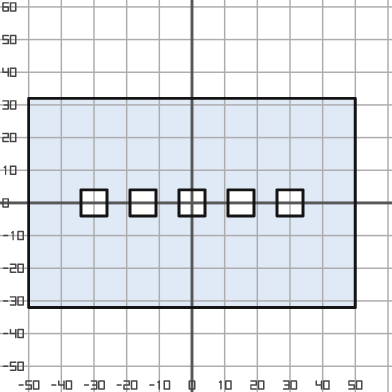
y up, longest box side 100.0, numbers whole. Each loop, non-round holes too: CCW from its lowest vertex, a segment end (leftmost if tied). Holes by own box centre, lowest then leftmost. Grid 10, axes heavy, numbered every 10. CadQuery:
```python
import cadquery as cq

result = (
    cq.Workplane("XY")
    .moveTo(-50.0, -32.0)
    .lineTo(50.0, -32.0)
    .lineTo(50.0, 32.0)
    .lineTo(-50.0, 32.0)
    .close()
    .moveTo(-34.0, -4.0)
    .lineTo(-26.0, -4.0)
    .lineTo(-26.0, 4.0)
    .lineTo(-34.0, 4.0)
    .close()
    .moveTo(-19.0, -4.0)
    .lineTo(-11.0, -4.0)
    .lineTo(-11.0, 4.0)
    .lineTo(-19.0, 4.0)
    .close()
    .moveTo(-4.0, -4.0)
    .lineTo(4.0, -4.0)
    .lineTo(4.0, 4.0)
    .lineTo(-4.0, 4.0)
    .close()
    .moveTo(11.0, -4.0)
    .lineTo(19.0, -4.0)
    .lineTo(19.0, 4.0)
    .lineTo(11.0, 4.0)
    .close()
    .moveTo(26.0, -4.0)
    .lineTo(34.0, -4.0)
    .lineTo(34.0, 4.0)
    .lineTo(26.0, 4.0)
    .close()
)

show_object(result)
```